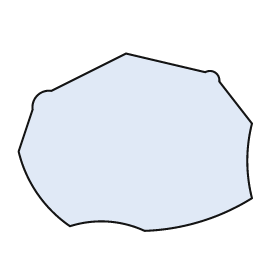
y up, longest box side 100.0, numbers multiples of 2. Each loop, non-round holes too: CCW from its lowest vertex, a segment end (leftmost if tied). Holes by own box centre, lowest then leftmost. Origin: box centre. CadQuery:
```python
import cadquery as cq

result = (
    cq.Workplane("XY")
    .moveTo(4.0, -38.0)
    .threePointArc((28.0, -34.0), (50.0, -24.0))
    .threePointArc((48.0, -8.0), (50.0, 8.0))
    .lineTo(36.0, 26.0)
    .threePointArc((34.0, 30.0), (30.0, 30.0))
    .lineTo(-4.0, 38.0)
    .lineTo(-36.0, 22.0)
    .threePointArc((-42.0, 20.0), (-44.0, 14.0))
    .lineTo(-50.0, -4.0)
    .threePointArc((-42.0, -22.0), (-28.0, -36.0))
    .threePointArc((-12.0, -34.0), (4.0, -38.0))
    .close()
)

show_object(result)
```